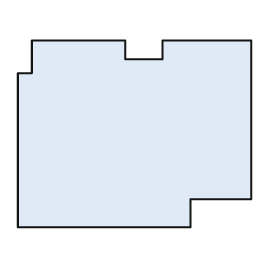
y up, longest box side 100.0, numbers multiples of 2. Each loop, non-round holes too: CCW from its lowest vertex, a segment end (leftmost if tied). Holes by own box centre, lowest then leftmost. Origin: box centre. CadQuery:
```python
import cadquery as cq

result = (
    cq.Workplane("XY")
    .moveTo(-50.0, -40.0)
    .lineTo(24.0, -40.0)
    .lineTo(24.0, -28.0)
    .lineTo(50.0, -28.0)
    .lineTo(50.0, 40.0)
    .lineTo(12.0, 40.0)
    .lineTo(12.0, 32.0)
    .lineTo(-4.0, 32.0)
    .lineTo(-4.0, 40.0)
    .lineTo(-44.0, 40.0)
    .lineTo(-44.0, 26.0)
    .lineTo(-50.0, 26.0)
    .close()
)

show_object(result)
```